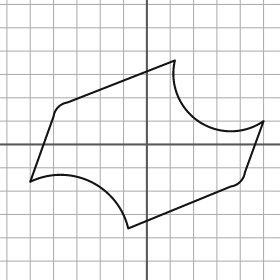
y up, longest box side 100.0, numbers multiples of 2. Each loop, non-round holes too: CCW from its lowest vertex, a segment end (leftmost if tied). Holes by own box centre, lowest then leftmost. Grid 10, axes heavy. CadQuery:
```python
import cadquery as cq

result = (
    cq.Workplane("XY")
    .moveTo(-8.0, -36.0)
    .lineTo(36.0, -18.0)
    .threePointArc((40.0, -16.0), (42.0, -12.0))
    .lineTo(50.0, 10.0)
    .threePointArc((22.0, 10.0), (12.0, 36.0))
    .lineTo(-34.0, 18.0)
    .threePointArc((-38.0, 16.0), (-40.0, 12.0))
    .lineTo(-50.0, -16.0)
    .threePointArc((-24.0, -16.0), (-8.0, -36.0))
    .close()
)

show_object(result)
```